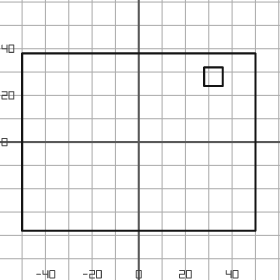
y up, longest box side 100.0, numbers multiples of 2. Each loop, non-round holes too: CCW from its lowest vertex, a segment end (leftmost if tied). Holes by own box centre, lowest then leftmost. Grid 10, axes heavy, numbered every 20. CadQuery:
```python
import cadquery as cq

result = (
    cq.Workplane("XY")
    .moveTo(-50.0, -38.0)
    .lineTo(50.0, -38.0)
    .lineTo(50.0, 38.0)
    .lineTo(-50.0, 38.0)
    .close()
    .moveTo(28.0, 24.0)
    .lineTo(36.0, 24.0)
    .lineTo(36.0, 32.0)
    .lineTo(28.0, 32.0)
    .close()
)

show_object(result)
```